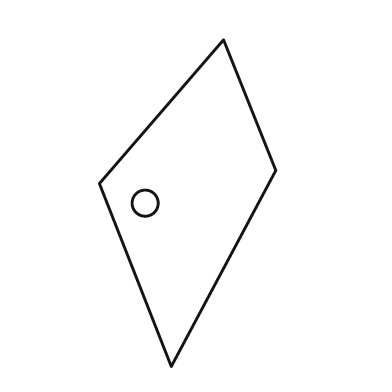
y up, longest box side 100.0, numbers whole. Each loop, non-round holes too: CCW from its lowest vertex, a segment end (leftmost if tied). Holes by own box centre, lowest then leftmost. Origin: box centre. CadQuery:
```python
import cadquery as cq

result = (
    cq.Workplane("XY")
    .moveTo(-5.0, -50.0)
    .lineTo(27.0, 10.0)
    .lineTo(11.0, 50.0)
    .lineTo(-27.0, 6.0)
    .close()
    .moveTo(-13.0, 0.0)
    .circle(4.0)
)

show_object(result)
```